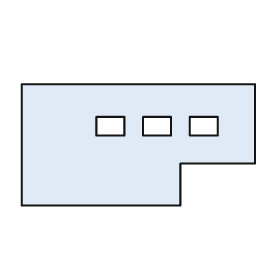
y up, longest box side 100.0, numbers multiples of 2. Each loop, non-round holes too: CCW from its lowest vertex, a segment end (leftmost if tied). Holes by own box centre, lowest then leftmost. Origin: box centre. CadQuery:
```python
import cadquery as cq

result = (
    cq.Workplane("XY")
    .moveTo(-50.0, -26.0)
    .lineTo(18.0, -26.0)
    .lineTo(18.0, -8.0)
    .lineTo(50.0, -8.0)
    .lineTo(50.0, 26.0)
    .lineTo(-50.0, 26.0)
    .close()
    .moveTo(-18.0, 4.0)
    .lineTo(-6.0, 4.0)
    .lineTo(-6.0, 12.0)
    .lineTo(-18.0, 12.0)
    .close()
    .moveTo(2.0, 4.0)
    .lineTo(14.0, 4.0)
    .lineTo(14.0, 12.0)
    .lineTo(2.0, 12.0)
    .close()
    .moveTo(22.0, 4.0)
    .lineTo(34.0, 4.0)
    .lineTo(34.0, 12.0)
    .lineTo(22.0, 12.0)
    .close()
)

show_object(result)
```